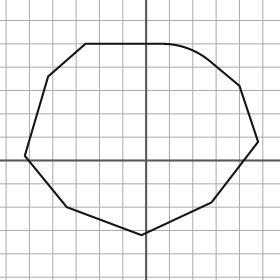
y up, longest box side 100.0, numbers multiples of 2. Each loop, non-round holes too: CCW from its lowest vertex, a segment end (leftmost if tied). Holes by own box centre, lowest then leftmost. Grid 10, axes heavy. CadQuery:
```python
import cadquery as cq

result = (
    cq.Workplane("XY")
    .moveTo(-2.0, -32.0)
    .lineTo(28.0, -18.0)
    .lineTo(48.0, 8.0)
    .lineTo(40.0, 32.0)
    .lineTo(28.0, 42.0)
    .threePointArc((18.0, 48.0), (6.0, 50.0))
    .lineTo(-26.0, 50.0)
    .lineTo(-42.0, 36.0)
    .lineTo(-52.0, 2.0)
    .lineTo(-34.0, -20.0)
    .close()
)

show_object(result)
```